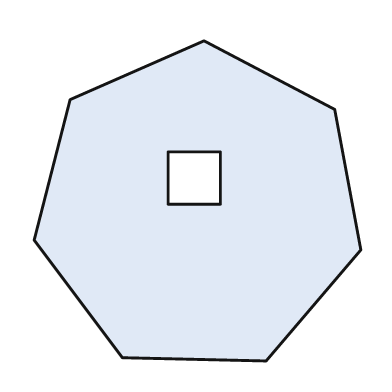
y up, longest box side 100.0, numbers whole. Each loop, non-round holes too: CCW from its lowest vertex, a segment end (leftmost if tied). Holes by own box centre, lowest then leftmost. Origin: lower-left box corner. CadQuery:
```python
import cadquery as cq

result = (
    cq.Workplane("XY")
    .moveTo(71.0, 0.0)
    .lineTo(100.0, 34.0)
    .lineTo(92.0, 77.0)
    .lineTo(52.0, 98.0)
    .lineTo(11.0, 80.0)
    .lineTo(0.0, 37.0)
    .lineTo(27.0, 1.0)
    .close()
    .moveTo(41.0, 48.0)
    .lineTo(57.0, 48.0)
    .lineTo(57.0, 64.0)
    .lineTo(41.0, 64.0)
    .close()
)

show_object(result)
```